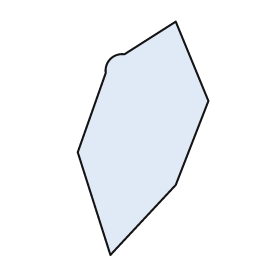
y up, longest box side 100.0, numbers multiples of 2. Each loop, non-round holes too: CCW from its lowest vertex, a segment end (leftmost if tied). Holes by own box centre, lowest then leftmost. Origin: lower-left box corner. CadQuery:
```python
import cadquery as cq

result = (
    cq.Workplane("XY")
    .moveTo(14.0, 0.0)
    .lineTo(42.0, 30.0)
    .lineTo(56.0, 66.0)
    .lineTo(42.0, 100.0)
    .lineTo(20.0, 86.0)
    .threePointArc((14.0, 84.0), (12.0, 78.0))
    .lineTo(0.0, 44.0)
    .close()
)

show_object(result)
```